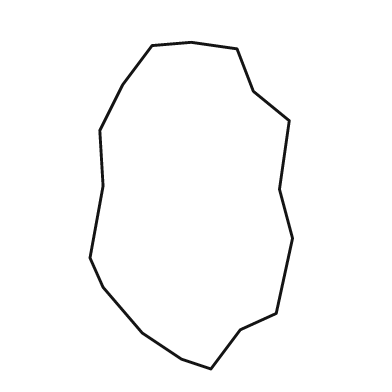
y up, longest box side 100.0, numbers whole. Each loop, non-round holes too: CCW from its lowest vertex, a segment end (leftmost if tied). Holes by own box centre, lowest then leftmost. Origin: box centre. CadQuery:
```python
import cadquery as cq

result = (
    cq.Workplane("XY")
    .moveTo(6.0, -50.0)
    .lineTo(15.0, -38.0)
    .lineTo(26.0, -33.0)
    .lineTo(31.0, -10.0)
    .lineTo(27.0, 5.0)
    .lineTo(30.0, 26.0)
    .lineTo(19.0, 35.0)
    .lineTo(14.0, 48.0)
    .lineTo(0.0, 50.0)
    .lineTo(-12.0, 49.0)
    .lineTo(-21.0, 37.0)
    .lineTo(-28.0, 23.0)
    .lineTo(-27.0, 6.0)
    .lineTo(-31.0, -16.0)
    .lineTo(-27.0, -25.0)
    .lineTo(-15.0, -39.0)
    .lineTo(-3.0, -47.0)
    .close()
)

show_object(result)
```